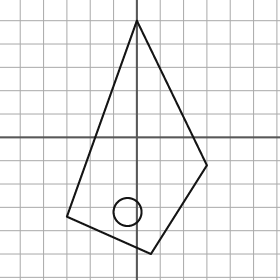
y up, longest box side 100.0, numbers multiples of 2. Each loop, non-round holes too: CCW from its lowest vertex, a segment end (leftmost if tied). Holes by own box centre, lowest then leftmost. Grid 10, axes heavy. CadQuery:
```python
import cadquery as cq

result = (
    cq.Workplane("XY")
    .moveTo(6.0, -50.0)
    .lineTo(30.0, -12.0)
    .lineTo(0.0, 50.0)
    .lineTo(-30.0, -34.0)
    .close()
    .moveTo(-4.0, -32.0)
    .circle(6.0)
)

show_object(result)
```